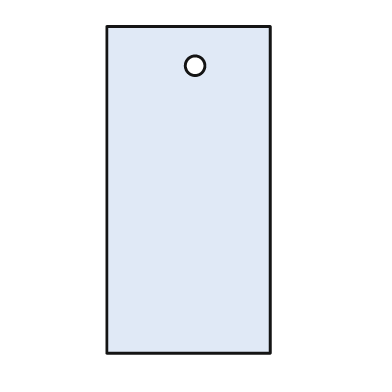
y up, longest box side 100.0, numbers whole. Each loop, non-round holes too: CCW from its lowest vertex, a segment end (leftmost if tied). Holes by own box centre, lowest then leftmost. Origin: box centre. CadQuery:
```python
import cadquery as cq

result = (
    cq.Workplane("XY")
    .moveTo(-25.0, -50.0)
    .lineTo(25.0, -50.0)
    .lineTo(25.0, 50.0)
    .lineTo(-25.0, 50.0)
    .close()
    .moveTo(2.0, 38.0)
    .circle(3.0)
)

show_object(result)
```